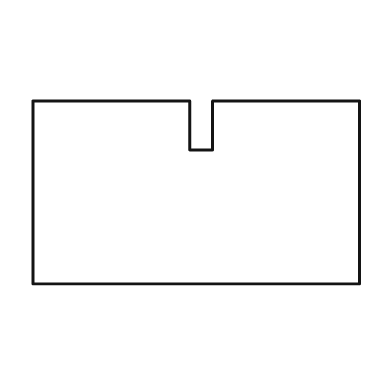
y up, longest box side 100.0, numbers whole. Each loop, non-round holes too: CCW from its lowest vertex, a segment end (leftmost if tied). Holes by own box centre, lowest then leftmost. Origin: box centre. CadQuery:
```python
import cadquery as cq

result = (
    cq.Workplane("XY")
    .moveTo(-50.0, -28.0)
    .lineTo(50.0, -28.0)
    .lineTo(50.0, 28.0)
    .lineTo(5.0, 28.0)
    .lineTo(5.0, 13.0)
    .lineTo(-2.0, 13.0)
    .lineTo(-2.0, 28.0)
    .lineTo(-50.0, 28.0)
    .close()
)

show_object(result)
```